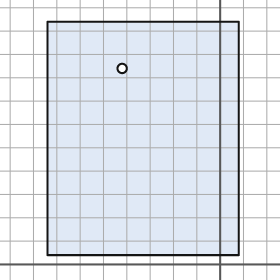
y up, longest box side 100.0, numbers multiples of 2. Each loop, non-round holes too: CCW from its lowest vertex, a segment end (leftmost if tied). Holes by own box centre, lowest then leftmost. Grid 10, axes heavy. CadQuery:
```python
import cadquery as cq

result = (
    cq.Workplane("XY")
    .moveTo(-74.0, 4.0)
    .lineTo(8.0, 4.0)
    .lineTo(8.0, 104.0)
    .lineTo(-74.0, 104.0)
    .close()
    .moveTo(-42.0, 84.0)
    .circle(2.0)
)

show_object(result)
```